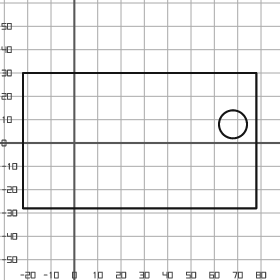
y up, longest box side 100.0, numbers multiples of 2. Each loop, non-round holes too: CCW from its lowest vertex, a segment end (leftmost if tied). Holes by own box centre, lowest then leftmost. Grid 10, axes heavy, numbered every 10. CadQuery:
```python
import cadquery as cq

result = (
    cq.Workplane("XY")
    .moveTo(-22.0, -28.0)
    .lineTo(78.0, -28.0)
    .lineTo(78.0, 30.0)
    .lineTo(-22.0, 30.0)
    .close()
    .moveTo(68.0, 8.0)
    .circle(6.0)
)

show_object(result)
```